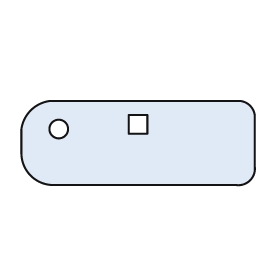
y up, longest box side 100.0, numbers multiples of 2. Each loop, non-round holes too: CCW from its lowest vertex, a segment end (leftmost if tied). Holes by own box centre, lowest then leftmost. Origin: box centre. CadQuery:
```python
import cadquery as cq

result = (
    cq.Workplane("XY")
    .moveTo(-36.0, -18.0)
    .lineTo(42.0, -18.0)
    .threePointArc((48.0, -16.0), (50.0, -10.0))
    .lineTo(50.0, 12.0)
    .threePointArc((48.0, 16.0), (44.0, 18.0))
    .lineTo(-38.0, 18.0)
    .threePointArc((-46.0, 14.0), (-50.0, 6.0))
    .lineTo(-50.0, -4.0)
    .threePointArc((-46.0, -14.0), (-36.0, -18.0))
    .close()
    .moveTo(-34.0, 6.0)
    .circle(4.0)
    .moveTo(-4.0, 4.0)
    .lineTo(4.0, 4.0)
    .lineTo(4.0, 12.0)
    .lineTo(-4.0, 12.0)
    .close()
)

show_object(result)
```